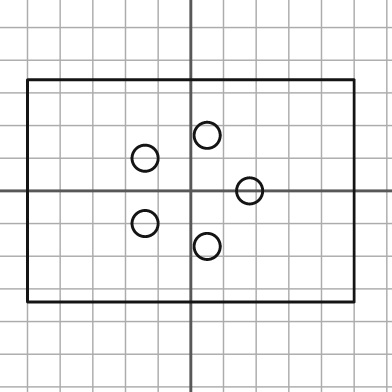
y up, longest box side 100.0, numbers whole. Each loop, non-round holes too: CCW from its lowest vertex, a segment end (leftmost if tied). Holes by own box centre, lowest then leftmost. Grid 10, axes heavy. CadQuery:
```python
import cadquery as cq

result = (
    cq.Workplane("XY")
    .moveTo(-50.0, -34.0)
    .lineTo(50.0, -34.0)
    .lineTo(50.0, 34.0)
    .lineTo(-50.0, 34.0)
    .close()
    .moveTo(5.0, -17.0)
    .circle(4.0)
    .moveTo(-14.0, -10.0)
    .circle(4.0)
    .moveTo(18.0, 0.0)
    .circle(4.0)
    .moveTo(-14.0, 10.0)
    .circle(4.0)
    .moveTo(5.0, 17.0)
    .circle(4.0)
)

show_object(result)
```